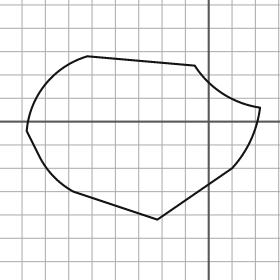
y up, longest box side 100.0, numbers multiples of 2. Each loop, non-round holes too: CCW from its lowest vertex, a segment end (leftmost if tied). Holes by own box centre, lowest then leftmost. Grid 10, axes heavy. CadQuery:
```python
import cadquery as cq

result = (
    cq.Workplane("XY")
    .moveTo(-22.0, -42.0)
    .lineTo(10.0, -20.0)
    .threePointArc((18.0, -8.0), (22.0, 6.0))
    .threePointArc((6.0, 12.0), (-6.0, 24.0))
    .lineTo(-52.0, 28.0)
    .threePointArc((-70.0, 16.0), (-78.0, -4.0))
    .lineTo(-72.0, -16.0)
    .threePointArc((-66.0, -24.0), (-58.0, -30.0))
    .close()
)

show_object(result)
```